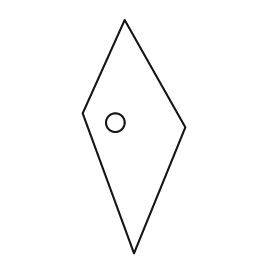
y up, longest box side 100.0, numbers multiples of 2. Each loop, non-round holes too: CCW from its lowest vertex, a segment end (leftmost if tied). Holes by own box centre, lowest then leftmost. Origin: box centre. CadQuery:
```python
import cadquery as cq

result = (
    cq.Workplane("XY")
    .moveTo(0.0, -50.0)
    .lineTo(22.0, 4.0)
    .lineTo(-4.0, 50.0)
    .lineTo(-22.0, 10.0)
    .close()
    .moveTo(-8.0, 6.0)
    .circle(4.0)
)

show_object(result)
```